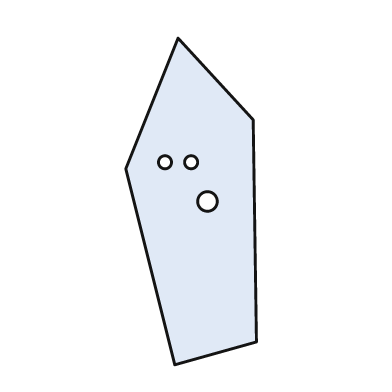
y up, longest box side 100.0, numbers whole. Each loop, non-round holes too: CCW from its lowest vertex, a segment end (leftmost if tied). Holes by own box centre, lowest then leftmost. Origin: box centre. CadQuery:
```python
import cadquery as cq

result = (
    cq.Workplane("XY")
    .moveTo(-5.0, -50.0)
    .lineTo(20.0, -43.0)
    .lineTo(19.0, 25.0)
    .lineTo(-4.0, 50.0)
    .lineTo(-20.0, 10.0)
    .close()
    .moveTo(5.0, 0.0)
    .circle(3.0)
    .moveTo(-8.0, 12.0)
    .circle(2.0)
    .moveTo(0.0, 12.0)
    .circle(2.0)
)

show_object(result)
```